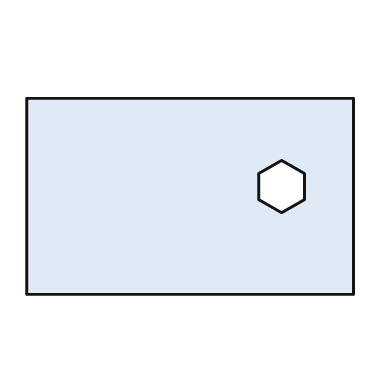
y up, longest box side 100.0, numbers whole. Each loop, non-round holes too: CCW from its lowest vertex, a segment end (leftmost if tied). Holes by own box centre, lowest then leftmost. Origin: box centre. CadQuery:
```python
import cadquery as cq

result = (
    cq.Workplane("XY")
    .moveTo(-50.0, -30.0)
    .lineTo(50.0, -30.0)
    .lineTo(50.0, 30.0)
    .lineTo(-50.0, 30.0)
    .close()
    .moveTo(28.0, -5.0)
    .lineTo(35.0, -1.0)
    .lineTo(35.0, 7.0)
    .lineTo(28.0, 11.0)
    .lineTo(21.0, 7.0)
    .lineTo(21.0, -1.0)
    .close()
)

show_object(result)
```